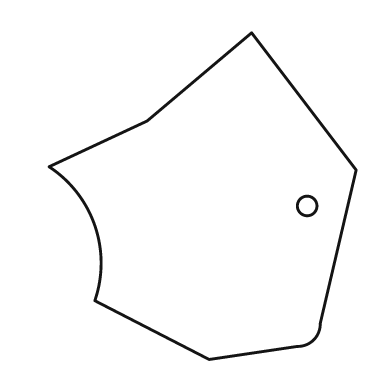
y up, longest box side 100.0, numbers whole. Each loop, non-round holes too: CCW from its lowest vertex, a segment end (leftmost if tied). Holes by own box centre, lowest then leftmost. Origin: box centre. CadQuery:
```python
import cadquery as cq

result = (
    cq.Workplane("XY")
    .moveTo(2.0, -50.0)
    .lineTo(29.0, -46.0)
    .threePointArc((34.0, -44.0), (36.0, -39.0))
    .lineTo(47.0, 8.0)
    .lineTo(15.0, 50.0)
    .lineTo(-17.0, 23.0)
    .lineTo(-47.0, 9.0)
    .threePointArc((-33.0, -9.0), (-33.0, -32.0))
    .close()
    .moveTo(32.0, -3.0)
    .circle(3.0)
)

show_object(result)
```